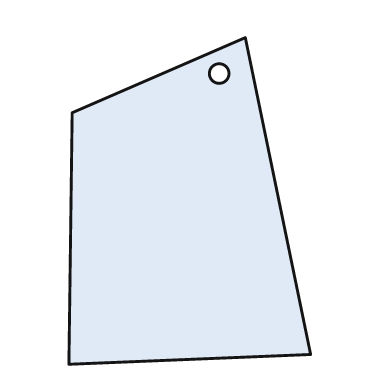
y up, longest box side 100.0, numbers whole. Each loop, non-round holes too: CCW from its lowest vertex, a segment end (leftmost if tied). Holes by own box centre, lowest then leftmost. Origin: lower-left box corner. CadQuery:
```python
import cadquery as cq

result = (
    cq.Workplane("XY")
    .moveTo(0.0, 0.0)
    .lineTo(74.0, 3.0)
    .lineTo(54.0, 100.0)
    .lineTo(1.0, 77.0)
    .close()
    .moveTo(46.0, 89.0)
    .circle(3.0)
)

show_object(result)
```